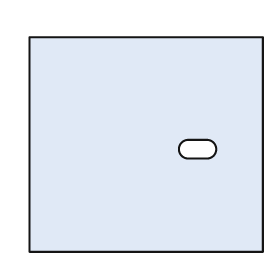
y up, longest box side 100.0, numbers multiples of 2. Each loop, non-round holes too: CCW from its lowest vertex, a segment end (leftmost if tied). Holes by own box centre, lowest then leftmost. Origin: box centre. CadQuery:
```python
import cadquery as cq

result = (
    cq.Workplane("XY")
    .moveTo(-50.0, -46.0)
    .lineTo(50.0, -46.0)
    .lineTo(50.0, 46.0)
    .lineTo(-50.0, 46.0)
    .close()
    .moveTo(18.0, -6.0)
    .lineTo(26.0, -6.0)
    .threePointArc((30.0, -2.0), (26.0, 2.0))
    .lineTo(18.0, 2.0)
    .threePointArc((14.0, -2.0), (18.0, -6.0))
    .close()
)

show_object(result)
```